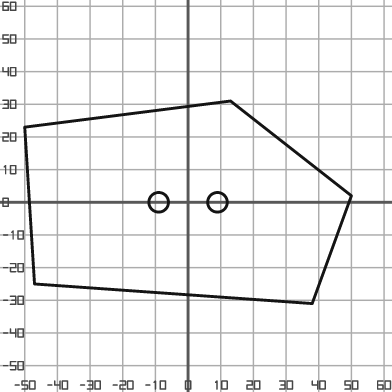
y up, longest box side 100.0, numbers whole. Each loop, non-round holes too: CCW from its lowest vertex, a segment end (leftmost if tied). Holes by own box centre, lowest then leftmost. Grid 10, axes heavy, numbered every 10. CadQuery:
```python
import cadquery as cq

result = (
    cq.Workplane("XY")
    .moveTo(38.0, -31.0)
    .lineTo(50.0, 2.0)
    .lineTo(13.0, 31.0)
    .lineTo(-50.0, 23.0)
    .lineTo(-47.0, -25.0)
    .close()
    .moveTo(-9.0, 0.0)
    .circle(3.0)
    .moveTo(9.0, 0.0)
    .circle(3.0)
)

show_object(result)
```